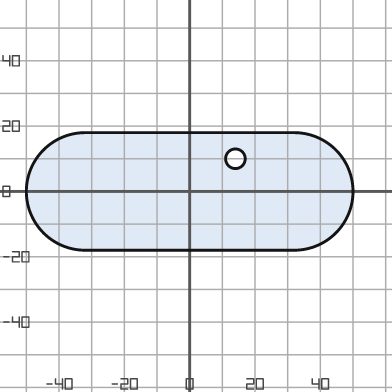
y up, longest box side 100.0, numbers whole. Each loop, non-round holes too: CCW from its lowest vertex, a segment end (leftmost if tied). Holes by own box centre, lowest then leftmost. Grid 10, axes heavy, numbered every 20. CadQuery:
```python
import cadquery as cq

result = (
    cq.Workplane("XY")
    .moveTo(-32.0, -18.0)
    .lineTo(32.0, -18.0)
    .threePointArc((50.0, 0.0), (32.0, 18.0))
    .lineTo(-32.0, 18.0)
    .threePointArc((-50.0, 0.0), (-32.0, -18.0))
    .close()
    .moveTo(14.0, 10.0)
    .circle(3.0)
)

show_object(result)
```